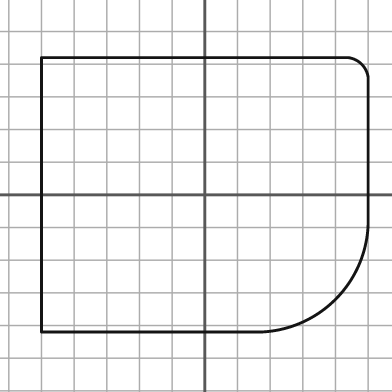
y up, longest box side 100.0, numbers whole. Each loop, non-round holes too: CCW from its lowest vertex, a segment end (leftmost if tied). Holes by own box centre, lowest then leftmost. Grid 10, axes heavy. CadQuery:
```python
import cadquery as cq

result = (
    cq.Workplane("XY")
    .moveTo(-50.0, -42.0)
    .lineTo(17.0, -42.0)
    .threePointArc((40.0, -32.0), (50.0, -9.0))
    .lineTo(50.0, 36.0)
    .threePointArc((48.0, 40.0), (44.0, 42.0))
    .lineTo(-50.0, 42.0)
    .close()
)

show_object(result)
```